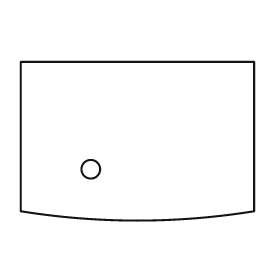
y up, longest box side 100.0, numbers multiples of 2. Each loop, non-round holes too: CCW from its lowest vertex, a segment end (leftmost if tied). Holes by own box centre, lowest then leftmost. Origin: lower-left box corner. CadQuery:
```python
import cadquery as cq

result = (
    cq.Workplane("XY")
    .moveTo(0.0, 4.0)
    .threePointArc((50.0, 0.0), (100.0, 4.0))
    .lineTo(100.0, 68.0)
    .lineTo(0.0, 68.0)
    .close()
    .moveTo(30.0, 22.0)
    .circle(4.0)
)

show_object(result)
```